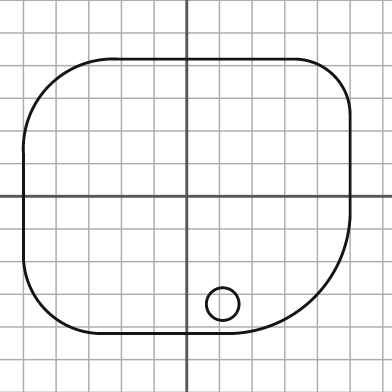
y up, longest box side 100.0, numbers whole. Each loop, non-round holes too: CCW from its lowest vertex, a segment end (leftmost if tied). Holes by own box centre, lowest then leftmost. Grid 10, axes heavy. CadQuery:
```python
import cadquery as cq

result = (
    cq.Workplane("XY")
    .moveTo(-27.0, -42.0)
    .lineTo(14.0, -42.0)
    .threePointArc((39.0, -31.0), (50.0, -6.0))
    .lineTo(50.0, 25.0)
    .threePointArc((45.0, 37.0), (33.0, 42.0))
    .lineTo(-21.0, 42.0)
    .threePointArc((-42.0, 34.0), (-50.0, 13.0))
    .lineTo(-50.0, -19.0)
    .threePointArc((-43.0, -35.0), (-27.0, -42.0))
    .close()
    .moveTo(11.0, -33.0)
    .circle(5.0)
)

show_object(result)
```